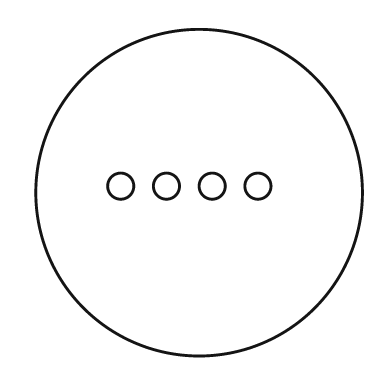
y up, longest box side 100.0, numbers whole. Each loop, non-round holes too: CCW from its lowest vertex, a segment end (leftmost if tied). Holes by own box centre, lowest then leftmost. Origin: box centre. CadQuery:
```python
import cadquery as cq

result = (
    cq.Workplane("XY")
    .moveTo(0.0, 0.0)
    .circle(50.0)
    .moveTo(-24.0, 2.0)
    .circle(4.0)
    .moveTo(-10.0, 2.0)
    .circle(4.0)
    .moveTo(4.0, 2.0)
    .circle(4.0)
    .moveTo(18.0, 2.0)
    .circle(4.0)
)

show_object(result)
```